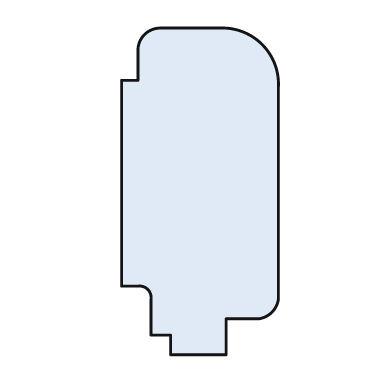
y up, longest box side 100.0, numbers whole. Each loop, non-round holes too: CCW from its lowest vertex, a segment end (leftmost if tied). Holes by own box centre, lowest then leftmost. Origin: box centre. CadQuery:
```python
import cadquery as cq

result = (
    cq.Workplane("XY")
    .moveTo(-9.0, -50.0)
    .lineTo(8.0, -50.0)
    .lineTo(8.0, -39.0)
    .lineTo(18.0, -39.0)
    .threePointArc((22.0, -37.0), (24.0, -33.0))
    .lineTo(24.0, 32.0)
    .threePointArc((19.0, 45.0), (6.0, 50.0))
    .lineTo(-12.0, 50.0)
    .threePointArc((-17.0, 48.0), (-19.0, 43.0))
    .lineTo(-19.0, 34.0)
    .lineTo(-24.0, 34.0)
    .lineTo(-24.0, -29.0)
    .lineTo(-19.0, -29.0)
    .threePointArc((-16.0, -30.0), (-15.0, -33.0))
    .lineTo(-15.0, -44.0)
    .lineTo(-9.0, -44.0)
    .close()
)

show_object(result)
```